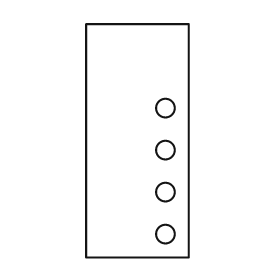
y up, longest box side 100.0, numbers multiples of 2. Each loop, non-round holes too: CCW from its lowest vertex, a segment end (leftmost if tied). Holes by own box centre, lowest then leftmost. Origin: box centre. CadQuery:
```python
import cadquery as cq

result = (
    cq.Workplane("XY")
    .moveTo(-22.0, -50.0)
    .lineTo(22.0, -50.0)
    .lineTo(22.0, 50.0)
    .lineTo(-22.0, 50.0)
    .close()
    .moveTo(12.0, -40.0)
    .circle(4.0)
    .moveTo(12.0, -22.0)
    .circle(4.0)
    .moveTo(12.0, -4.0)
    .circle(4.0)
    .moveTo(12.0, 14.0)
    .circle(4.0)
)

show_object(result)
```